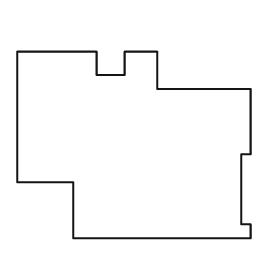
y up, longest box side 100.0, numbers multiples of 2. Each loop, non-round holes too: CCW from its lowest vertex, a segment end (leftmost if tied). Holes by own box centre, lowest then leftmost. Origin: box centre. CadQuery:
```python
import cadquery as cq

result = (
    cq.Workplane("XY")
    .moveTo(-26.0, -40.0)
    .lineTo(50.0, -40.0)
    .lineTo(50.0, -34.0)
    .lineTo(46.0, -34.0)
    .lineTo(46.0, -4.0)
    .lineTo(50.0, -4.0)
    .lineTo(50.0, 24.0)
    .lineTo(10.0, 24.0)
    .lineTo(10.0, 40.0)
    .lineTo(-4.0, 40.0)
    .lineTo(-4.0, 30.0)
    .lineTo(-16.0, 30.0)
    .lineTo(-16.0, 40.0)
    .lineTo(-50.0, 40.0)
    .lineTo(-50.0, -16.0)
    .lineTo(-26.0, -16.0)
    .close()
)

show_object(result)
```